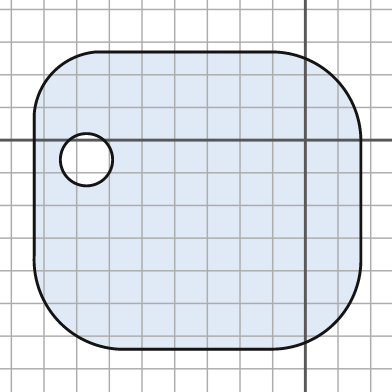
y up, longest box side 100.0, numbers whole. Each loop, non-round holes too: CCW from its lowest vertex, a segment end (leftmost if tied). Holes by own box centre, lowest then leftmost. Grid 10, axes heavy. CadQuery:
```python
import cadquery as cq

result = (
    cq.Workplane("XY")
    .moveTo(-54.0, -64.0)
    .lineTo(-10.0, -64.0)
    .threePointArc((9.0, -56.0), (17.0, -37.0))
    .lineTo(17.0, 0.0)
    .threePointArc((9.0, 19.0), (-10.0, 27.0))
    .lineTo(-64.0, 27.0)
    .threePointArc((-77.0, 21.0), (-83.0, 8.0))
    .lineTo(-83.0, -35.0)
    .threePointArc((-75.0, -56.0), (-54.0, -64.0))
    .close()
    .moveTo(-67.0, -6.0)
    .circle(8.0)
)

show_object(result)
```